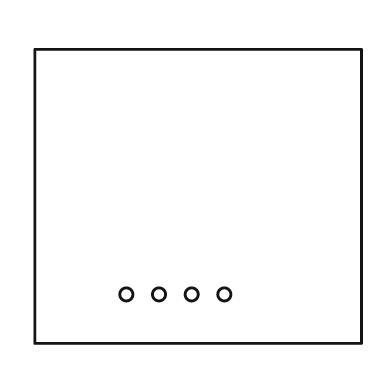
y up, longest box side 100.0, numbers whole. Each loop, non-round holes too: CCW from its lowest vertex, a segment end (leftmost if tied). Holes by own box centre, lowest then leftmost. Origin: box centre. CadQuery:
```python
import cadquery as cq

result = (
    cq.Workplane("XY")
    .moveTo(-50.0, -45.0)
    .lineTo(50.0, -45.0)
    .lineTo(50.0, 45.0)
    .lineTo(-50.0, 45.0)
    .close()
    .moveTo(-22.0, -30.0)
    .circle(2.0)
    .moveTo(-12.0, -30.0)
    .circle(2.0)
    .moveTo(-2.0, -30.0)
    .circle(2.0)
    .moveTo(8.0, -30.0)
    .circle(2.0)
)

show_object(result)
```